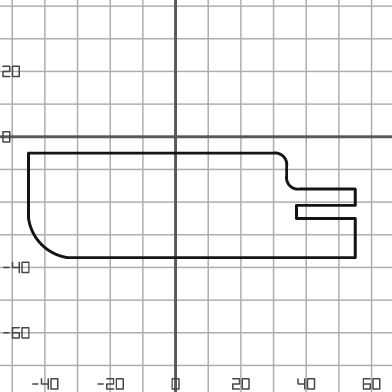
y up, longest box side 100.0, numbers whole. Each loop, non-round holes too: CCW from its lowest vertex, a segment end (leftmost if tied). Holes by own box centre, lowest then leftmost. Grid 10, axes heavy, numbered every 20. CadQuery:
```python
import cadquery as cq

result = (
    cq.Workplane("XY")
    .moveTo(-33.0, -37.0)
    .lineTo(55.0, -37.0)
    .lineTo(55.0, -25.0)
    .lineTo(37.0, -25.0)
    .lineTo(37.0, -21.0)
    .lineTo(55.0, -21.0)
    .lineTo(55.0, -16.0)
    .lineTo(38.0, -16.0)
    .threePointArc((35.0, -15.0), (34.0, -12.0))
    .lineTo(34.0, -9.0)
    .threePointArc((33.0, -6.0), (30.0, -5.0))
    .lineTo(-45.0, -5.0)
    .lineTo(-45.0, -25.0)
    .threePointArc((-41.0, -33.0), (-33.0, -37.0))
    .close()
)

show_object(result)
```